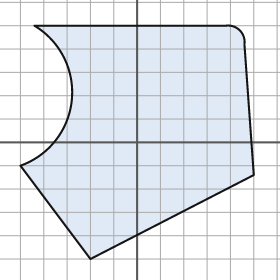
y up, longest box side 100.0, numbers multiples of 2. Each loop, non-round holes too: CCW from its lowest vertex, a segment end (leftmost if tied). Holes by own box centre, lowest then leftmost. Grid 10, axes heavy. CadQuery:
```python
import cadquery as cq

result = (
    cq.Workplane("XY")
    .moveTo(-20.0, -50.0)
    .lineTo(50.0, -14.0)
    .lineTo(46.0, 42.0)
    .threePointArc((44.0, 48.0), (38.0, 50.0))
    .lineTo(-44.0, 50.0)
    .threePointArc((-28.0, 18.0), (-50.0, -10.0))
    .close()
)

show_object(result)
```